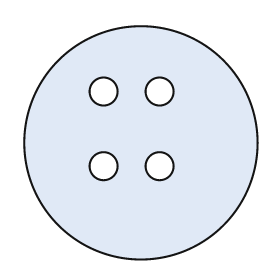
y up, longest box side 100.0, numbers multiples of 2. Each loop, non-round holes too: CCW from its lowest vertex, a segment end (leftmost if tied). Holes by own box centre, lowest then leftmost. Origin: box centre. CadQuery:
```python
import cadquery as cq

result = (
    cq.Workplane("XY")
    .moveTo(0.0, 0.0)
    .circle(50.0)
    .moveTo(-16.0, -10.0)
    .circle(6.0)
    .moveTo(8.0, -10.0)
    .circle(6.0)
    .moveTo(-16.0, 22.0)
    .circle(6.0)
    .moveTo(8.0, 22.0)
    .circle(6.0)
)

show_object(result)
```